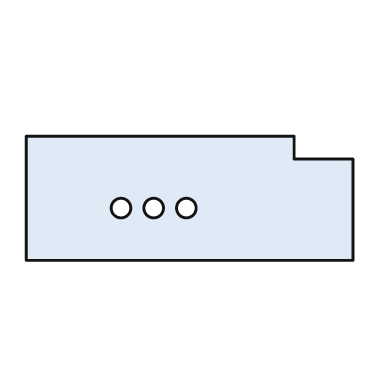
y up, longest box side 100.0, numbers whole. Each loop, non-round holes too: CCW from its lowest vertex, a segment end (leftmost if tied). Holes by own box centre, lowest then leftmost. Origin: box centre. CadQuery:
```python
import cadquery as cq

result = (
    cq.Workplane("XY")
    .moveTo(-50.0, -19.0)
    .lineTo(50.0, -19.0)
    .lineTo(50.0, 12.0)
    .lineTo(32.0, 12.0)
    .lineTo(32.0, 19.0)
    .lineTo(-50.0, 19.0)
    .close()
    .moveTo(-21.0, -3.0)
    .circle(3.0)
    .moveTo(-11.0, -3.0)
    .circle(3.0)
    .moveTo(-1.0, -3.0)
    .circle(3.0)
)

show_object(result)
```